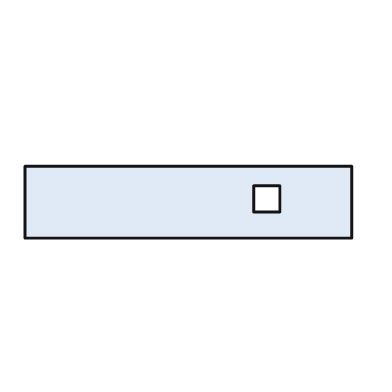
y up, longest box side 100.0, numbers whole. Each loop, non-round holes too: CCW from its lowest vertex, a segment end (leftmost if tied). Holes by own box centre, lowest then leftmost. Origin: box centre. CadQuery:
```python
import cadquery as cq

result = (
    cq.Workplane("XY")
    .moveTo(-50.0, -11.0)
    .lineTo(50.0, -11.0)
    .lineTo(50.0, 11.0)
    .lineTo(-50.0, 11.0)
    .close()
    .moveTo(20.0, -3.0)
    .lineTo(28.0, -3.0)
    .lineTo(28.0, 5.0)
    .lineTo(20.0, 5.0)
    .close()
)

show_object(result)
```